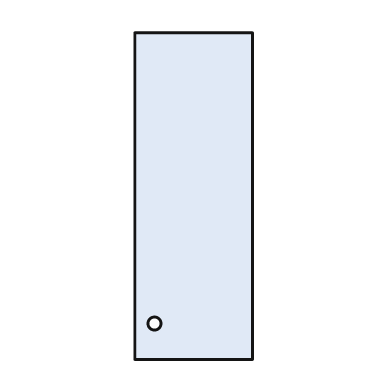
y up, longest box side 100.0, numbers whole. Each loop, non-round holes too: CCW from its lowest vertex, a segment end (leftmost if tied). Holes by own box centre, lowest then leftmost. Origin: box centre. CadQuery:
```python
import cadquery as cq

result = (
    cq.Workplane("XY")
    .moveTo(-18.0, -50.0)
    .lineTo(18.0, -50.0)
    .lineTo(18.0, 50.0)
    .lineTo(-18.0, 50.0)
    .close()
    .moveTo(-12.0, -39.0)
    .circle(2.0)
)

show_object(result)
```